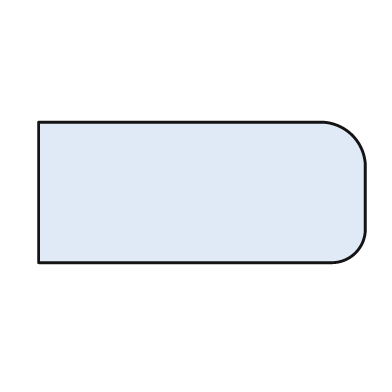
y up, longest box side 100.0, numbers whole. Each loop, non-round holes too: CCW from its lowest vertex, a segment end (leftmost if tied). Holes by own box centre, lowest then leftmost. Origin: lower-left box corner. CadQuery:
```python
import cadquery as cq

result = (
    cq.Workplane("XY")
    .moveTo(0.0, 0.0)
    .lineTo(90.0, 0.0)
    .threePointArc((97.0, 3.0), (100.0, 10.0))
    .lineTo(100.0, 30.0)
    .threePointArc((96.0, 39.0), (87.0, 43.0))
    .lineTo(0.0, 43.0)
    .close()
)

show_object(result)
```